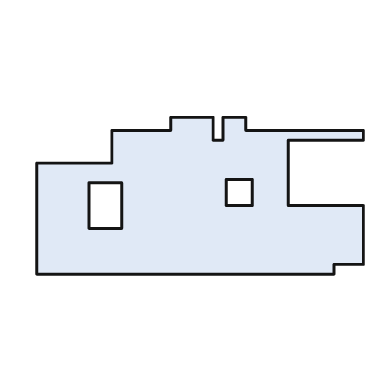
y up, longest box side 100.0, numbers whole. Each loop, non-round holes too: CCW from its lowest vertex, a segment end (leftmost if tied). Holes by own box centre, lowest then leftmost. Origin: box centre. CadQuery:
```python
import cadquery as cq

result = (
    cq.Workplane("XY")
    .moveTo(-50.0, -24.0)
    .lineTo(41.0, -24.0)
    .lineTo(41.0, -21.0)
    .lineTo(50.0, -21.0)
    .lineTo(50.0, -3.0)
    .lineTo(27.0, -3.0)
    .lineTo(27.0, 17.0)
    .lineTo(50.0, 17.0)
    .lineTo(50.0, 20.0)
    .lineTo(14.0, 20.0)
    .lineTo(14.0, 24.0)
    .lineTo(7.0, 24.0)
    .lineTo(7.0, 17.0)
    .lineTo(4.0, 17.0)
    .lineTo(4.0, 24.0)
    .lineTo(-9.0, 24.0)
    .lineTo(-9.0, 20.0)
    .lineTo(-27.0, 20.0)
    .lineTo(-27.0, 10.0)
    .lineTo(-50.0, 10.0)
    .close()
    .moveTo(-34.0, -10.0)
    .lineTo(-24.0, -10.0)
    .lineTo(-24.0, 4.0)
    .lineTo(-34.0, 4.0)
    .close()
    .moveTo(8.0, -3.0)
    .lineTo(16.0, -3.0)
    .lineTo(16.0, 5.0)
    .lineTo(8.0, 5.0)
    .close()
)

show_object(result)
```